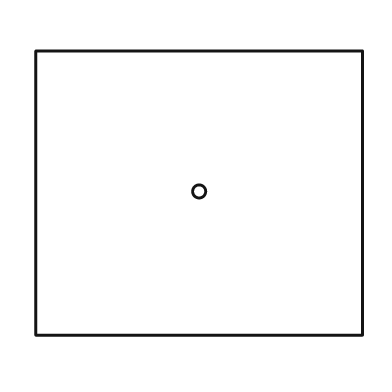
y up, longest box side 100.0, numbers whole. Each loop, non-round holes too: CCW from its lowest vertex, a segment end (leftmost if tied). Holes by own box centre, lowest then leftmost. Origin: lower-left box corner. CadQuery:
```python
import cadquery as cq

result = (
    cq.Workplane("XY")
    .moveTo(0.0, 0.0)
    .lineTo(100.0, 0.0)
    .lineTo(100.0, 87.0)
    .lineTo(0.0, 87.0)
    .close()
    .moveTo(50.0, 44.0)
    .circle(2.0)
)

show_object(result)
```